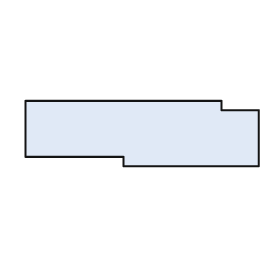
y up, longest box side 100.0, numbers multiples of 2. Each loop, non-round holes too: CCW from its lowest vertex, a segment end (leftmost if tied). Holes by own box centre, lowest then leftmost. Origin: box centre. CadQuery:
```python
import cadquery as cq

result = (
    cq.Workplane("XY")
    .moveTo(-8.0, -14.0)
    .lineTo(50.0, -14.0)
    .lineTo(50.0, 10.0)
    .lineTo(34.0, 10.0)
    .lineTo(34.0, 14.0)
    .lineTo(-50.0, 14.0)
    .lineTo(-50.0, -10.0)
    .lineTo(-8.0, -10.0)
    .close()
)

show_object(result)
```